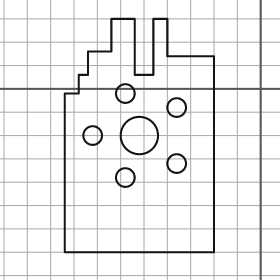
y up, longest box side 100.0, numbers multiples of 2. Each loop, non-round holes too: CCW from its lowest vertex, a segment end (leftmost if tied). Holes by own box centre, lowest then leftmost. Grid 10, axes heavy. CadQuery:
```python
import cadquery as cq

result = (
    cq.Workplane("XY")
    .moveTo(-84.0, -70.0)
    .lineTo(-20.0, -70.0)
    .lineTo(-20.0, 14.0)
    .lineTo(-40.0, 14.0)
    .lineTo(-40.0, 30.0)
    .lineTo(-46.0, 30.0)
    .lineTo(-46.0, 6.0)
    .lineTo(-54.0, 6.0)
    .lineTo(-54.0, 30.0)
    .lineTo(-64.0, 30.0)
    .lineTo(-64.0, 16.0)
    .lineTo(-74.0, 16.0)
    .lineTo(-74.0, 6.0)
    .lineTo(-78.0, 6.0)
    .lineTo(-78.0, -2.0)
    .lineTo(-84.0, -2.0)
    .close()
    .moveTo(-58.0, -38.0)
    .circle(4.0)
    .moveTo(-36.0, -32.0)
    .circle(4.0)
    .moveTo(-72.0, -20.0)
    .circle(4.0)
    .moveTo(-52.0, -20.0)
    .circle(8.0)
    .moveTo(-36.0, -8.0)
    .circle(4.0)
    .moveTo(-58.0, -2.0)
    .circle(4.0)
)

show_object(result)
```